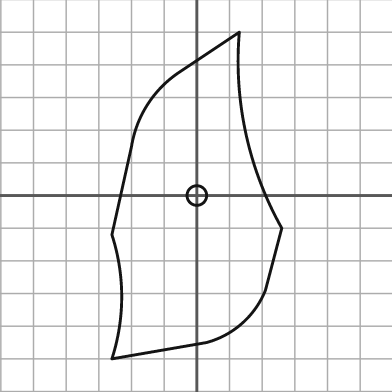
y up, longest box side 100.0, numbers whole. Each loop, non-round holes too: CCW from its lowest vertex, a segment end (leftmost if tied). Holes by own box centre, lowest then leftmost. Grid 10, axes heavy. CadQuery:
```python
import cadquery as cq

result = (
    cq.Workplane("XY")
    .moveTo(-26.0, -50.0)
    .lineTo(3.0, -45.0)
    .threePointArc((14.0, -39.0), (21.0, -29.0))
    .lineTo(26.0, -10.0)
    .threePointArc((15.0, 19.0), (13.0, 50.0))
    .lineTo(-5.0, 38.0)
    .threePointArc((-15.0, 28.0), (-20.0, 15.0))
    .lineTo(-26.0, -12.0)
    .threePointArc((-23.0, -31.0), (-26.0, -50.0))
    .close()
    .moveTo(0.0, 0.0)
    .circle(3.0)
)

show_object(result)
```